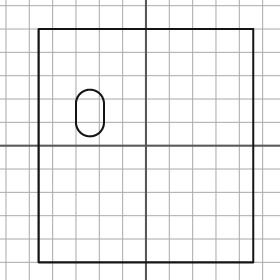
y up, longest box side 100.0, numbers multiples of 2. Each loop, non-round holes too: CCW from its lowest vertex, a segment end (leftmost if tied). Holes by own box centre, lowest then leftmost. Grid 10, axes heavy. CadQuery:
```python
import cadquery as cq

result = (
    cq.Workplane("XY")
    .moveTo(-46.0, -50.0)
    .lineTo(46.0, -50.0)
    .lineTo(46.0, 50.0)
    .lineTo(-46.0, 50.0)
    .close()
    .moveTo(-30.0, 10.0)
    .threePointArc((-24.0, 4.0), (-18.0, 10.0))
    .lineTo(-18.0, 18.0)
    .threePointArc((-24.0, 24.0), (-30.0, 18.0))
    .close()
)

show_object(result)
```